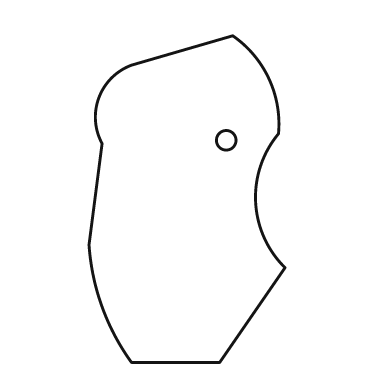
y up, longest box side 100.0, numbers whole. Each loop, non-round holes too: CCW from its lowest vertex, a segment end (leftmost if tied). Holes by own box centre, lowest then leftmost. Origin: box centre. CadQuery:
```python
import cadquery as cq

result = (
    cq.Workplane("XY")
    .moveTo(-17.0, -50.0)
    .lineTo(10.0, -50.0)
    .lineTo(30.0, -21.0)
    .threePointArc((21.0, -1.0), (28.0, 20.0))
    .threePointArc((25.0, 37.0), (14.0, 50.0))
    .lineTo(-17.0, 41.0)
    .threePointArc((-27.0, 31.0), (-26.0, 17.0))
    .lineTo(-30.0, -14.0)
    .threePointArc((-26.0, -33.0), (-17.0, -50.0))
    .close()
    .moveTo(12.0, 18.0)
    .circle(3.0)
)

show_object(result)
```